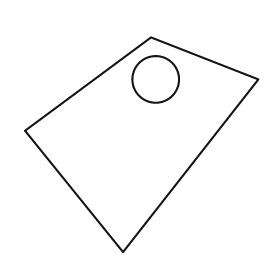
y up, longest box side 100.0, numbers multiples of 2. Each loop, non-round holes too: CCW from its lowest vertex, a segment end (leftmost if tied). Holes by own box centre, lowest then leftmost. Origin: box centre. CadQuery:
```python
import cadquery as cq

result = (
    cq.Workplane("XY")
    .moveTo(-8.0, -46.0)
    .lineTo(50.0, 28.0)
    .lineTo(4.0, 46.0)
    .lineTo(-50.0, 6.0)
    .close()
    .moveTo(6.0, 28.0)
    .circle(10.0)
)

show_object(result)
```